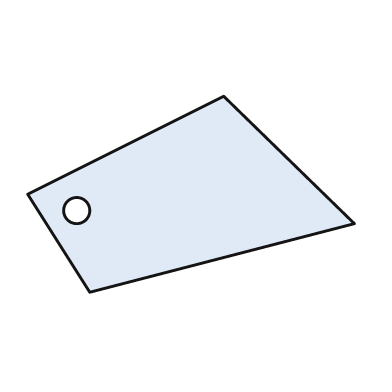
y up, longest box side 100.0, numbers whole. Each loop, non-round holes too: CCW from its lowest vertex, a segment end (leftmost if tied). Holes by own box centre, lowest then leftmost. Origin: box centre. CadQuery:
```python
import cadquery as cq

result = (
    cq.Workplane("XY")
    .moveTo(-31.0, -30.0)
    .lineTo(50.0, -9.0)
    .lineTo(10.0, 30.0)
    .lineTo(-50.0, 0.0)
    .close()
    .moveTo(-35.0, -5.0)
    .circle(4.0)
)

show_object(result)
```